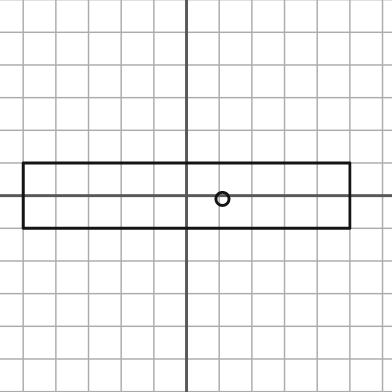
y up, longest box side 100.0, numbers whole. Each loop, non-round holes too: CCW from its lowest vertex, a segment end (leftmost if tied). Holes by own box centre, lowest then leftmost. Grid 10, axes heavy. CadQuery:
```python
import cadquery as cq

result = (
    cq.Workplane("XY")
    .moveTo(-50.0, -10.0)
    .lineTo(50.0, -10.0)
    .lineTo(50.0, 10.0)
    .lineTo(-50.0, 10.0)
    .close()
    .moveTo(11.0, -1.0)
    .circle(2.0)
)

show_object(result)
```